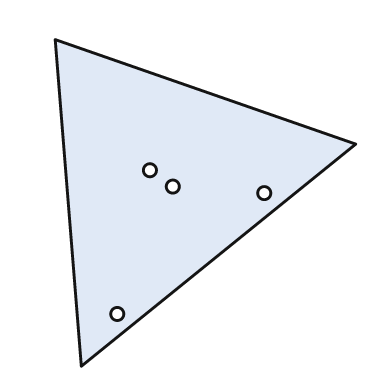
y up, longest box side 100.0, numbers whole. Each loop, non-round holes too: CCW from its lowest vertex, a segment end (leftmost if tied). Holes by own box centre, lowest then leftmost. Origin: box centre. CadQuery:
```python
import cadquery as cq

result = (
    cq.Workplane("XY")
    .moveTo(-38.0, -50.0)
    .lineTo(46.0, 18.0)
    .lineTo(-46.0, 50.0)
    .close()
    .moveTo(-27.0, -34.0)
    .circle(2.0)
    .moveTo(18.0, 3.0)
    .circle(2.0)
    .moveTo(-10.0, 5.0)
    .circle(2.0)
    .moveTo(-17.0, 10.0)
    .circle(2.0)
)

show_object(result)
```